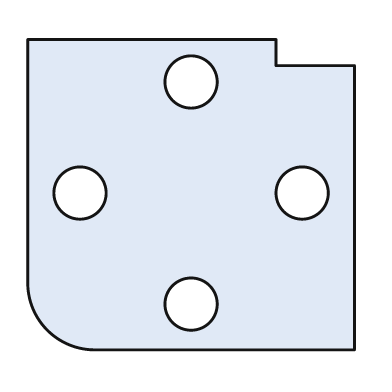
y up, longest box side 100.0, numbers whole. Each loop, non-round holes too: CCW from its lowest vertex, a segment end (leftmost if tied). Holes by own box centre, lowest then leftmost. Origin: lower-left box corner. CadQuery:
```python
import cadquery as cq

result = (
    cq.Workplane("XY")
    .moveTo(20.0, 0.0)
    .lineTo(100.0, 0.0)
    .lineTo(100.0, 87.0)
    .lineTo(76.0, 87.0)
    .lineTo(76.0, 95.0)
    .lineTo(0.0, 95.0)
    .lineTo(0.0, 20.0)
    .threePointArc((6.0, 6.0), (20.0, 0.0))
    .close()
    .moveTo(50.0, 14.0)
    .circle(8.0)
    .moveTo(16.0, 48.0)
    .circle(8.0)
    .moveTo(84.0, 48.0)
    .circle(8.0)
    .moveTo(50.0, 82.0)
    .circle(8.0)
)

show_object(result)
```